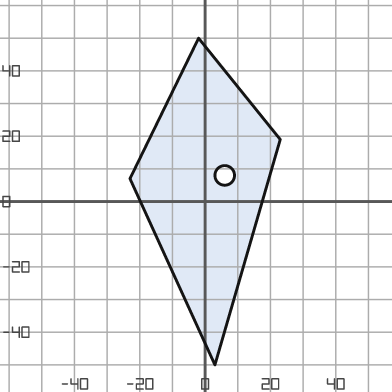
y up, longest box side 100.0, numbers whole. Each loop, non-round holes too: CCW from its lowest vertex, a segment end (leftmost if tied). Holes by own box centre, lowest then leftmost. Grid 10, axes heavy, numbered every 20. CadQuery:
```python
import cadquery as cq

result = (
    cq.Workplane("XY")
    .moveTo(3.0, -50.0)
    .lineTo(23.0, 19.0)
    .lineTo(-2.0, 50.0)
    .lineTo(-23.0, 7.0)
    .close()
    .moveTo(6.0, 8.0)
    .circle(3.0)
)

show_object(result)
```